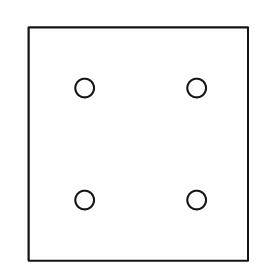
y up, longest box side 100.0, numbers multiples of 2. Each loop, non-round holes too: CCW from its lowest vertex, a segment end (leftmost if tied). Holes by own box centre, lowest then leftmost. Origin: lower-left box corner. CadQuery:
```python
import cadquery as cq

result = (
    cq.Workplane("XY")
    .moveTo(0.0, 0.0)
    .lineTo(94.0, 0.0)
    .lineTo(94.0, 100.0)
    .lineTo(0.0, 100.0)
    .close()
    .moveTo(24.0, 26.0)
    .circle(4.0)
    .moveTo(72.0, 26.0)
    .circle(4.0)
    .moveTo(24.0, 74.0)
    .circle(4.0)
    .moveTo(72.0, 74.0)
    .circle(4.0)
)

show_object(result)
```